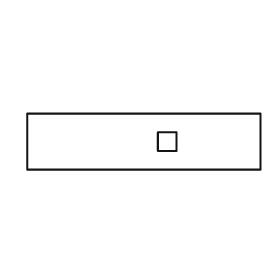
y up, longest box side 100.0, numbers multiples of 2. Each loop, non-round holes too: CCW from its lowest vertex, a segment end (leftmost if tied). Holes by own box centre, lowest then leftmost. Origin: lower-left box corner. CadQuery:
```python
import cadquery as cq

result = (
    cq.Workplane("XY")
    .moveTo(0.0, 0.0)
    .lineTo(100.0, 0.0)
    .lineTo(100.0, 24.0)
    .lineTo(0.0, 24.0)
    .close()
    .moveTo(56.0, 8.0)
    .lineTo(64.0, 8.0)
    .lineTo(64.0, 16.0)
    .lineTo(56.0, 16.0)
    .close()
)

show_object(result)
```